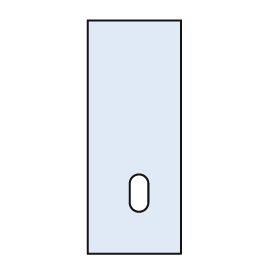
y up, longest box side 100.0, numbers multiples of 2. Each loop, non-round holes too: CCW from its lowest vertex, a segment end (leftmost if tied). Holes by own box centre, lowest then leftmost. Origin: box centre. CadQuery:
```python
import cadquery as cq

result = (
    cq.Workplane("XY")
    .moveTo(-20.0, -50.0)
    .lineTo(20.0, -50.0)
    .lineTo(20.0, 50.0)
    .lineTo(-20.0, 50.0)
    .close()
    .moveTo(-2.0, -28.0)
    .threePointArc((2.0, -32.0), (6.0, -28.0))
    .lineTo(6.0, -20.0)
    .threePointArc((2.0, -16.0), (-2.0, -20.0))
    .close()
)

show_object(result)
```